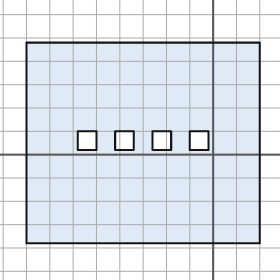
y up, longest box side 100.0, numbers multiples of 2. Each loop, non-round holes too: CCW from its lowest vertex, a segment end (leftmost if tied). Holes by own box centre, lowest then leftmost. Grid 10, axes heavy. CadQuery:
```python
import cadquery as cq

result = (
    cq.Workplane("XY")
    .moveTo(-80.0, -38.0)
    .lineTo(20.0, -38.0)
    .lineTo(20.0, 48.0)
    .lineTo(-80.0, 48.0)
    .close()
    .moveTo(-58.0, 2.0)
    .lineTo(-50.0, 2.0)
    .lineTo(-50.0, 10.0)
    .lineTo(-58.0, 10.0)
    .close()
    .moveTo(-42.0, 2.0)
    .lineTo(-34.0, 2.0)
    .lineTo(-34.0, 10.0)
    .lineTo(-42.0, 10.0)
    .close()
    .moveTo(-26.0, 2.0)
    .lineTo(-18.0, 2.0)
    .lineTo(-18.0, 10.0)
    .lineTo(-26.0, 10.0)
    .close()
    .moveTo(-10.0, 2.0)
    .lineTo(-2.0, 2.0)
    .lineTo(-2.0, 10.0)
    .lineTo(-10.0, 10.0)
    .close()
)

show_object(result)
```